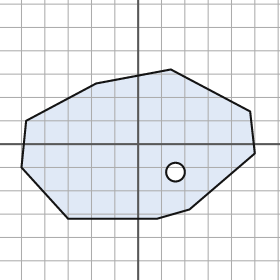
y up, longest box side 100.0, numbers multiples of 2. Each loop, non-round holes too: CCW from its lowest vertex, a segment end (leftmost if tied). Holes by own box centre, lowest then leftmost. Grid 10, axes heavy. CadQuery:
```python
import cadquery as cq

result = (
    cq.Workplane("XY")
    .moveTo(-30.0, -32.0)
    .lineTo(8.0, -32.0)
    .lineTo(22.0, -28.0)
    .lineTo(50.0, -4.0)
    .lineTo(48.0, 14.0)
    .lineTo(14.0, 32.0)
    .lineTo(-18.0, 26.0)
    .lineTo(-48.0, 10.0)
    .lineTo(-50.0, -10.0)
    .close()
    .moveTo(16.0, -12.0)
    .circle(4.0)
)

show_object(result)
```